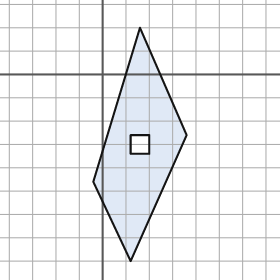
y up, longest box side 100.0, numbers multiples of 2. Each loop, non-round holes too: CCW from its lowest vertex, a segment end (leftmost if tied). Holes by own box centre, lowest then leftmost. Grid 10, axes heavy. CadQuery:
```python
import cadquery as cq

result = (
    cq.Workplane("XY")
    .moveTo(12.0, -80.0)
    .lineTo(36.0, -26.0)
    .lineTo(16.0, 20.0)
    .lineTo(-4.0, -46.0)
    .close()
    .moveTo(12.0, -34.0)
    .lineTo(20.0, -34.0)
    .lineTo(20.0, -26.0)
    .lineTo(12.0, -26.0)
    .close()
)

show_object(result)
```